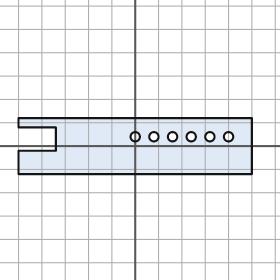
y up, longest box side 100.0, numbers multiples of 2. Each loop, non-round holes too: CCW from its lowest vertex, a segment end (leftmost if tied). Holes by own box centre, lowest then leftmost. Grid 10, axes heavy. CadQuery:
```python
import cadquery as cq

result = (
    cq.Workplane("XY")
    .moveTo(-50.0, -12.0)
    .lineTo(50.0, -12.0)
    .lineTo(50.0, 12.0)
    .lineTo(-50.0, 12.0)
    .lineTo(-50.0, 8.0)
    .lineTo(-34.0, 8.0)
    .lineTo(-34.0, -2.0)
    .lineTo(-50.0, -2.0)
    .close()
    .moveTo(0.0, 4.0)
    .circle(2.0)
    .moveTo(8.0, 4.0)
    .circle(2.0)
    .moveTo(16.0, 4.0)
    .circle(2.0)
    .moveTo(24.0, 4.0)
    .circle(2.0)
    .moveTo(32.0, 4.0)
    .circle(2.0)
    .moveTo(40.0, 4.0)
    .circle(2.0)
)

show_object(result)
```